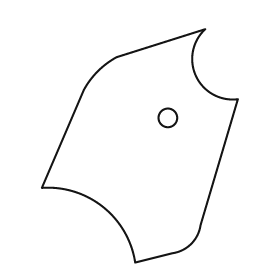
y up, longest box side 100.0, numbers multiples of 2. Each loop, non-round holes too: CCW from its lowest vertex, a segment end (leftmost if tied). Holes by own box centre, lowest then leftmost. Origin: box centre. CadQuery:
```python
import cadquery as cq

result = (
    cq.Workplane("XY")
    .moveTo(-2.0, -50.0)
    .lineTo(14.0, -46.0)
    .threePointArc((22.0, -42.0), (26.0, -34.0))
    .lineTo(42.0, 20.0)
    .threePointArc((24.0, 30.0), (28.0, 50.0))
    .lineTo(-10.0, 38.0)
    .threePointArc((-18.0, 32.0), (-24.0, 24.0))
    .lineTo(-42.0, -18.0)
    .threePointArc((-16.0, -26.0), (-2.0, -50.0))
    .close()
    .moveTo(12.0, 12.0)
    .circle(4.0)
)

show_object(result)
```